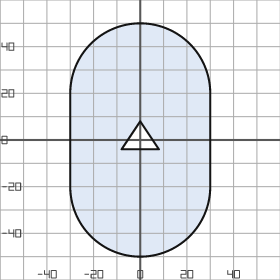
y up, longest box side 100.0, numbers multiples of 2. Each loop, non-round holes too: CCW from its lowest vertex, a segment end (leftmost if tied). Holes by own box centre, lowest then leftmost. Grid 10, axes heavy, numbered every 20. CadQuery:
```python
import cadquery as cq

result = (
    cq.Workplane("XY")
    .moveTo(-30.0, -20.0)
    .threePointArc((0.0, -50.0), (30.0, -20.0))
    .lineTo(30.0, 20.0)
    .threePointArc((0.0, 50.0), (-30.0, 20.0))
    .close()
    .moveTo(-8.0, -4.0)
    .lineTo(8.0, -4.0)
    .lineTo(0.0, 8.0)
    .close()
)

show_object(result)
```